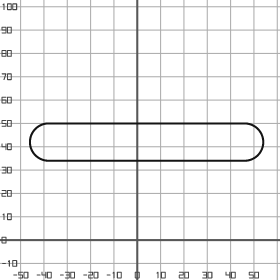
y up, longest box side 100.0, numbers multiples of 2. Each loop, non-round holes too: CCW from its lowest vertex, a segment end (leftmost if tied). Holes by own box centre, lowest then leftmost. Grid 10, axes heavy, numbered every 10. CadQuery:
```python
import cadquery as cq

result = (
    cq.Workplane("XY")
    .moveTo(-38.0, 34.0)
    .lineTo(46.0, 34.0)
    .threePointArc((54.0, 42.0), (46.0, 50.0))
    .lineTo(-38.0, 50.0)
    .threePointArc((-46.0, 42.0), (-38.0, 34.0))
    .close()
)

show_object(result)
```